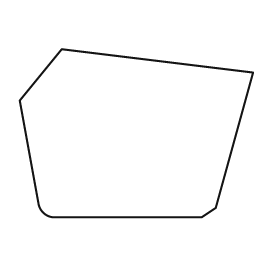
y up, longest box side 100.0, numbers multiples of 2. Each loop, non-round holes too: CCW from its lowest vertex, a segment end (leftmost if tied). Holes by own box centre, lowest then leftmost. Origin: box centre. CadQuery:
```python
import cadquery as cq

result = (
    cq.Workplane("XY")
    .moveTo(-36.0, -36.0)
    .lineTo(28.0, -36.0)
    .lineTo(34.0, -32.0)
    .lineTo(50.0, 26.0)
    .lineTo(-32.0, 36.0)
    .lineTo(-50.0, 14.0)
    .lineTo(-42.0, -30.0)
    .threePointArc((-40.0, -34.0), (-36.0, -36.0))
    .close()
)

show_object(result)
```